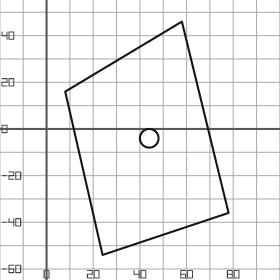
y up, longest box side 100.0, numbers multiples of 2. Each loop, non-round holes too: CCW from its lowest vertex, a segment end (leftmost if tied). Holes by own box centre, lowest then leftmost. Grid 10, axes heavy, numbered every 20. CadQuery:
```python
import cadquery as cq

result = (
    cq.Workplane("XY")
    .moveTo(24.0, -54.0)
    .lineTo(78.0, -36.0)
    .lineTo(58.0, 46.0)
    .lineTo(8.0, 16.0)
    .close()
    .moveTo(44.0, -4.0)
    .circle(4.0)
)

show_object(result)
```